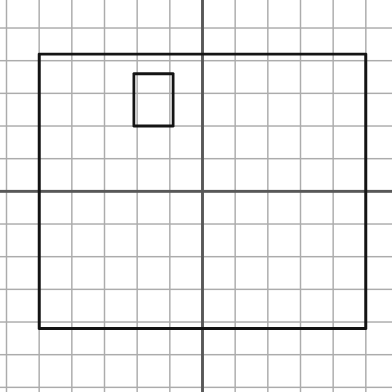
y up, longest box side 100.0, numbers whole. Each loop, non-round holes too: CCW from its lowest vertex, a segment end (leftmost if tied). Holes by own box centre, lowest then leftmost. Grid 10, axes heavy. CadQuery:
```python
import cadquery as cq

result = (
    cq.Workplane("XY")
    .moveTo(-50.0, -42.0)
    .lineTo(50.0, -42.0)
    .lineTo(50.0, 42.0)
    .lineTo(-50.0, 42.0)
    .close()
    .moveTo(-21.0, 20.0)
    .lineTo(-9.0, 20.0)
    .lineTo(-9.0, 36.0)
    .lineTo(-21.0, 36.0)
    .close()
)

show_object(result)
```